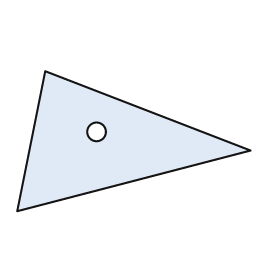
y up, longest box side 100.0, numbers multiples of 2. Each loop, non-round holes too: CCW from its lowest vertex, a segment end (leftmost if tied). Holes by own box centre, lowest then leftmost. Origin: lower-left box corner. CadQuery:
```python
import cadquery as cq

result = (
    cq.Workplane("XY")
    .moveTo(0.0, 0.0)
    .lineTo(100.0, 26.0)
    .lineTo(12.0, 60.0)
    .close()
    .moveTo(34.0, 34.0)
    .circle(4.0)
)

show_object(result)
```